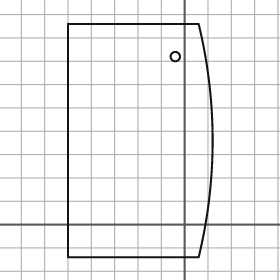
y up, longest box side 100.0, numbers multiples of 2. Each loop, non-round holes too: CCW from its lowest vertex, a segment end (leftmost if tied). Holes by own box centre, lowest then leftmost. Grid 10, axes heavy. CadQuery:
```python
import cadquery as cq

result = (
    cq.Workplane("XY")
    .moveTo(-50.0, -14.0)
    .lineTo(6.0, -14.0)
    .threePointArc((12.0, 36.0), (6.0, 86.0))
    .lineTo(-50.0, 86.0)
    .close()
    .moveTo(-4.0, 72.0)
    .circle(2.0)
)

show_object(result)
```